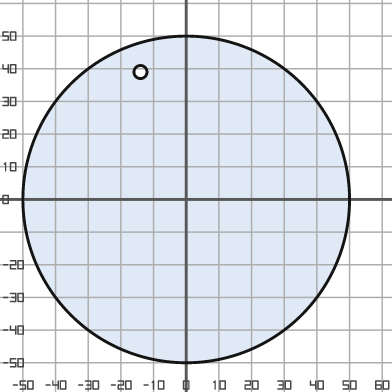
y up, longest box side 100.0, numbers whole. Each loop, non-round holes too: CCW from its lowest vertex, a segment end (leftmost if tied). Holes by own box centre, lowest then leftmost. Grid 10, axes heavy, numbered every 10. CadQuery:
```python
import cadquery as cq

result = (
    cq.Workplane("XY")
    .moveTo(0.0, 0.0)
    .circle(50.0)
    .moveTo(-14.0, 39.0)
    .circle(2.0)
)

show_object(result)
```